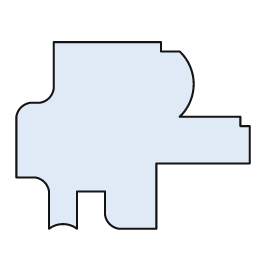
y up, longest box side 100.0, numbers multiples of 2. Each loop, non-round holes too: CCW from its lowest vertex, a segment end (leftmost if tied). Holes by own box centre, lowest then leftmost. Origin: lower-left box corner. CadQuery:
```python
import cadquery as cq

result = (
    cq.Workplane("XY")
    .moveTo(14.0, 0.0)
    .threePointArc((20.0, 2.0), (26.0, 0.0))
    .lineTo(26.0, 16.0)
    .lineTo(38.0, 16.0)
    .lineTo(38.0, 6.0)
    .threePointArc((40.0, 2.0), (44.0, 0.0))
    .lineTo(60.0, 0.0)
    .lineTo(60.0, 28.0)
    .lineTo(100.0, 28.0)
    .lineTo(100.0, 44.0)
    .lineTo(96.0, 44.0)
    .lineTo(96.0, 48.0)
    .lineTo(70.0, 48.0)
    .threePointArc((76.0, 62.0), (70.0, 76.0))
    .lineTo(62.0, 76.0)
    .lineTo(62.0, 80.0)
    .lineTo(16.0, 80.0)
    .lineTo(16.0, 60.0)
    .threePointArc((14.0, 56.0), (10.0, 54.0))
    .lineTo(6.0, 54.0)
    .threePointArc((2.0, 52.0), (0.0, 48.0))
    .lineTo(0.0, 22.0)
    .lineTo(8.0, 22.0)
    .threePointArc((12.0, 20.0), (14.0, 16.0))
    .close()
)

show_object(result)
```